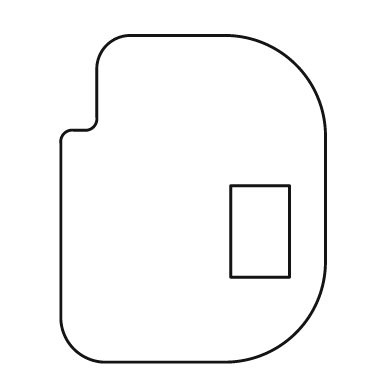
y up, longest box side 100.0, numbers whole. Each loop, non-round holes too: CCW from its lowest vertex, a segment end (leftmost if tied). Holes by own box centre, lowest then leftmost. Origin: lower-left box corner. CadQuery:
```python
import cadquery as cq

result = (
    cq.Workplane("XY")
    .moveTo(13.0, 0.0)
    .lineTo(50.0, 0.0)
    .threePointArc((72.0, 9.0), (81.0, 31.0))
    .lineTo(81.0, 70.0)
    .threePointArc((72.0, 91.0), (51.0, 100.0))
    .lineTo(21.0, 100.0)
    .threePointArc((14.0, 97.0), (11.0, 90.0))
    .lineTo(11.0, 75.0)
    .threePointArc((10.0, 72.0), (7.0, 71.0))
    .lineTo(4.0, 71.0)
    .threePointArc((1.0, 70.0), (0.0, 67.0))
    .lineTo(0.0, 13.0)
    .threePointArc((4.0, 4.0), (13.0, 0.0))
    .close()
    .moveTo(52.0, 26.0)
    .lineTo(70.0, 26.0)
    .lineTo(70.0, 54.0)
    .lineTo(52.0, 54.0)
    .close()
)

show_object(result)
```